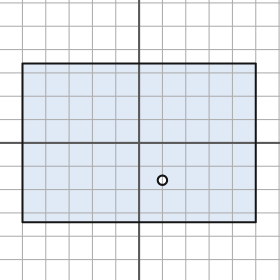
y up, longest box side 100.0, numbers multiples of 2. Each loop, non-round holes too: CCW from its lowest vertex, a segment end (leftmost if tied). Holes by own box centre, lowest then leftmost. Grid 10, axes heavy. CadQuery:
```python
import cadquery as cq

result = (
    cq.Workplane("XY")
    .moveTo(-50.0, -34.0)
    .lineTo(50.0, -34.0)
    .lineTo(50.0, 34.0)
    .lineTo(-50.0, 34.0)
    .close()
    .moveTo(10.0, -16.0)
    .circle(2.0)
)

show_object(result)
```